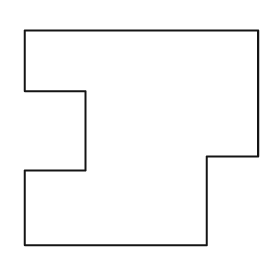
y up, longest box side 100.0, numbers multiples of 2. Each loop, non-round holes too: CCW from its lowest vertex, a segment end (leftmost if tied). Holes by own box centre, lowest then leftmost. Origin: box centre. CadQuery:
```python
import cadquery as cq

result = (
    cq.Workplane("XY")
    .moveTo(-50.0, -46.0)
    .lineTo(28.0, -46.0)
    .lineTo(28.0, -8.0)
    .lineTo(50.0, -8.0)
    .lineTo(50.0, 46.0)
    .lineTo(-50.0, 46.0)
    .lineTo(-50.0, 20.0)
    .lineTo(-24.0, 20.0)
    .lineTo(-24.0, -14.0)
    .lineTo(-50.0, -14.0)
    .close()
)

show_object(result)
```